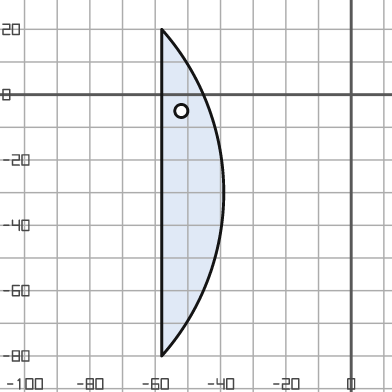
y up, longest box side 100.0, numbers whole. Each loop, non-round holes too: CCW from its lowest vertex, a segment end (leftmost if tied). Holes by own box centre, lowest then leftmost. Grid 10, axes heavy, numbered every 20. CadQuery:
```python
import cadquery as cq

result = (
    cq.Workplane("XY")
    .moveTo(-58.0, -80.0)
    .threePointArc((-39.0, -30.0), (-58.0, 20.0))
    .close()
    .moveTo(-52.0, -5.0)
    .circle(2.0)
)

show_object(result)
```